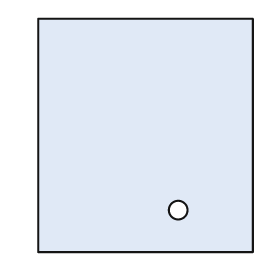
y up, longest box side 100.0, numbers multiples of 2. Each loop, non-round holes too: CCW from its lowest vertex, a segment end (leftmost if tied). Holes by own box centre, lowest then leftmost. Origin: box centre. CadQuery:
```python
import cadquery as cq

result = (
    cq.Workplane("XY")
    .moveTo(-46.0, -50.0)
    .lineTo(46.0, -50.0)
    .lineTo(46.0, 50.0)
    .lineTo(-46.0, 50.0)
    .close()
    .moveTo(14.0, -32.0)
    .circle(4.0)
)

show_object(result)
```